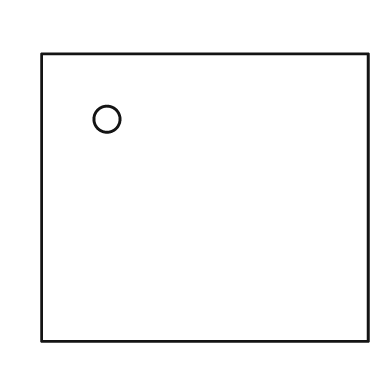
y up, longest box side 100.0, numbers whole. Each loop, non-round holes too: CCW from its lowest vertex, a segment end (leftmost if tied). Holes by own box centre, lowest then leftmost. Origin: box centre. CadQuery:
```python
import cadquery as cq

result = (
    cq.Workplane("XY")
    .moveTo(-50.0, -44.0)
    .lineTo(50.0, -44.0)
    .lineTo(50.0, 44.0)
    .lineTo(-50.0, 44.0)
    .close()
    .moveTo(-30.0, 24.0)
    .circle(4.0)
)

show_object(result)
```